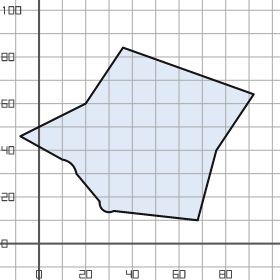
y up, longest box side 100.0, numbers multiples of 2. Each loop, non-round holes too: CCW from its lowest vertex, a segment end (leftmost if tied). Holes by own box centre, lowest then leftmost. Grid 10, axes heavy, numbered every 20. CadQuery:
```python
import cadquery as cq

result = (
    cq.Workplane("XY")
    .moveTo(68.0, 10.0)
    .lineTo(76.0, 40.0)
    .lineTo(92.0, 64.0)
    .lineTo(36.0, 84.0)
    .lineTo(20.0, 60.0)
    .lineTo(-8.0, 46.0)
    .lineTo(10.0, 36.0)
    .threePointArc((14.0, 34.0), (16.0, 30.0))
    .lineTo(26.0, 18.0)
    .threePointArc((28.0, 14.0), (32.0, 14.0))
    .close()
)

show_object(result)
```